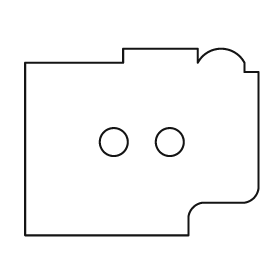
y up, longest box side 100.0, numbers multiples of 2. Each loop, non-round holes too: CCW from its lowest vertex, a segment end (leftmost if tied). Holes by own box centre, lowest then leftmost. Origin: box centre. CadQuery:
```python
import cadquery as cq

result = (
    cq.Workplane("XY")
    .moveTo(-50.0, -40.0)
    .lineTo(20.0, -40.0)
    .lineTo(20.0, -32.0)
    .threePointArc((22.0, -28.0), (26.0, -26.0))
    .lineTo(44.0, -26.0)
    .threePointArc((48.0, -24.0), (50.0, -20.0))
    .lineTo(50.0, 30.0)
    .lineTo(44.0, 30.0)
    .lineTo(44.0, 34.0)
    .threePointArc((34.0, 40.0), (24.0, 34.0))
    .lineTo(24.0, 40.0)
    .lineTo(-8.0, 40.0)
    .lineTo(-8.0, 34.0)
    .lineTo(-50.0, 34.0)
    .close()
    .moveTo(-12.0, 0.0)
    .circle(6.0)
    .moveTo(12.0, 0.0)
    .circle(6.0)
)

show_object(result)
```